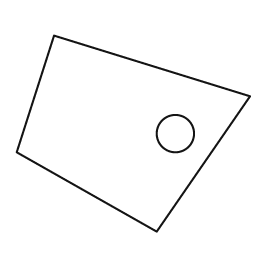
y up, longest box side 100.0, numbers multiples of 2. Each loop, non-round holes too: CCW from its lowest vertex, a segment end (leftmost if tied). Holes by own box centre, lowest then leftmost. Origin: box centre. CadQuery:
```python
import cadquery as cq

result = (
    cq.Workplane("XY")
    .moveTo(10.0, -42.0)
    .lineTo(50.0, 16.0)
    .lineTo(-34.0, 42.0)
    .lineTo(-50.0, -8.0)
    .close()
    .moveTo(18.0, 0.0)
    .circle(8.0)
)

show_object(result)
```